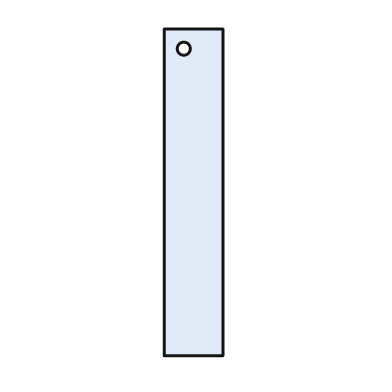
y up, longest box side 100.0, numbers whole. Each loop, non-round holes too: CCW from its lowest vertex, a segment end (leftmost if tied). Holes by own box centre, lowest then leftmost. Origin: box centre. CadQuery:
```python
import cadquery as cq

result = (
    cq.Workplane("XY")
    .moveTo(-9.0, -50.0)
    .lineTo(9.0, -50.0)
    .lineTo(9.0, 50.0)
    .lineTo(-9.0, 50.0)
    .close()
    .moveTo(-3.0, 44.0)
    .circle(2.0)
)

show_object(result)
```